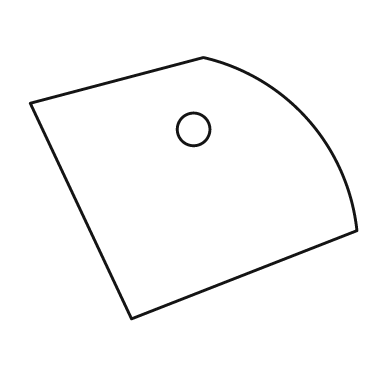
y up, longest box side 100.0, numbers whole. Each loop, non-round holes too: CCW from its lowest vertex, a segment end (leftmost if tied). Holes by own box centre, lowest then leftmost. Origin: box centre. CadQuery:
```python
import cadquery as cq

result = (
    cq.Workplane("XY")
    .moveTo(-19.0, -40.0)
    .lineTo(50.0, -13.0)
    .threePointArc((35.0, 21.0), (3.0, 40.0))
    .lineTo(-50.0, 26.0)
    .close()
    .moveTo(0.0, 18.0)
    .circle(5.0)
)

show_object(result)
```